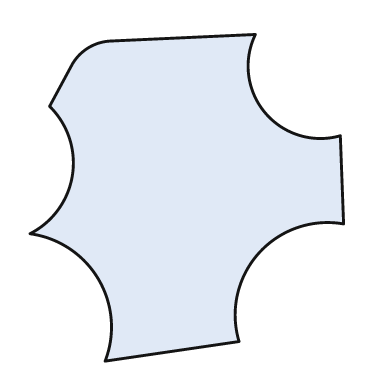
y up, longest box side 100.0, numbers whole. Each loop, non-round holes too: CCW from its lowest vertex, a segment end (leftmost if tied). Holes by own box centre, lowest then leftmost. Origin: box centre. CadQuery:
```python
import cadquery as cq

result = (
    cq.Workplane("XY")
    .moveTo(-25.0, -50.0)
    .lineTo(16.0, -44.0)
    .threePointArc((22.0, -17.0), (48.0, -8.0))
    .lineTo(47.0, 19.0)
    .threePointArc((24.0, 26.0), (21.0, 50.0))
    .lineTo(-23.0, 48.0)
    .threePointArc((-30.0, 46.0), (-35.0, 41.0))
    .lineTo(-42.0, 28.0)
    .threePointArc((-35.0, 7.0), (-48.0, -11.0))
    .threePointArc((-27.0, -25.0), (-25.0, -50.0))
    .close()
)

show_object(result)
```